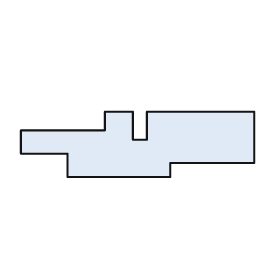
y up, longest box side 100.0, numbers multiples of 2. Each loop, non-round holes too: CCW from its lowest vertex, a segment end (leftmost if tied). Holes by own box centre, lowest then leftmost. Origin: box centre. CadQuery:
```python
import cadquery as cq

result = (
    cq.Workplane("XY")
    .moveTo(-30.0, -14.0)
    .lineTo(14.0, -14.0)
    .lineTo(14.0, -8.0)
    .lineTo(50.0, -8.0)
    .lineTo(50.0, 14.0)
    .lineTo(4.0, 14.0)
    .lineTo(4.0, 2.0)
    .lineTo(-2.0, 2.0)
    .lineTo(-2.0, 14.0)
    .lineTo(-14.0, 14.0)
    .lineTo(-14.0, 6.0)
    .lineTo(-50.0, 6.0)
    .lineTo(-50.0, -4.0)
    .lineTo(-30.0, -4.0)
    .close()
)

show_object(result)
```